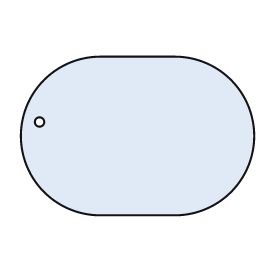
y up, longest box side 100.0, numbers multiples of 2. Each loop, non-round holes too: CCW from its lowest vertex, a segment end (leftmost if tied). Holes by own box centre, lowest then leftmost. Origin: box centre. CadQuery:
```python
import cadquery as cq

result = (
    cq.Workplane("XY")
    .moveTo(-16.0, -34.0)
    .lineTo(16.0, -34.0)
    .threePointArc((50.0, 0.0), (16.0, 34.0))
    .lineTo(-16.0, 34.0)
    .threePointArc((-50.0, 0.0), (-16.0, -34.0))
    .close()
    .moveTo(-42.0, 6.0)
    .circle(2.0)
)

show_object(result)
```